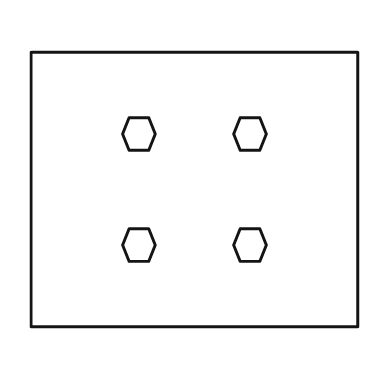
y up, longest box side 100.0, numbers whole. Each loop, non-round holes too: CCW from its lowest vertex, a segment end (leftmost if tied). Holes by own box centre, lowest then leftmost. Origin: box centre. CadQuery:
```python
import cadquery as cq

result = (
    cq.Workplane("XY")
    .moveTo(-50.0, -42.0)
    .lineTo(50.0, -42.0)
    .lineTo(50.0, 42.0)
    .lineTo(-50.0, 42.0)
    .close()
    .moveTo(-20.0, -22.0)
    .lineTo(-14.0, -22.0)
    .lineTo(-12.0, -17.0)
    .lineTo(-14.0, -12.0)
    .lineTo(-20.0, -12.0)
    .lineTo(-22.0, -17.0)
    .close()
    .moveTo(14.0, -22.0)
    .lineTo(20.0, -22.0)
    .lineTo(22.0, -17.0)
    .lineTo(20.0, -12.0)
    .lineTo(14.0, -12.0)
    .lineTo(12.0, -17.0)
    .close()
    .moveTo(-20.0, 12.0)
    .lineTo(-14.0, 12.0)
    .lineTo(-12.0, 17.0)
    .lineTo(-14.0, 22.0)
    .lineTo(-20.0, 22.0)
    .lineTo(-22.0, 17.0)
    .close()
    .moveTo(14.0, 12.0)
    .lineTo(20.0, 12.0)
    .lineTo(22.0, 17.0)
    .lineTo(20.0, 22.0)
    .lineTo(14.0, 22.0)
    .lineTo(12.0, 17.0)
    .close()
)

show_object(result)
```